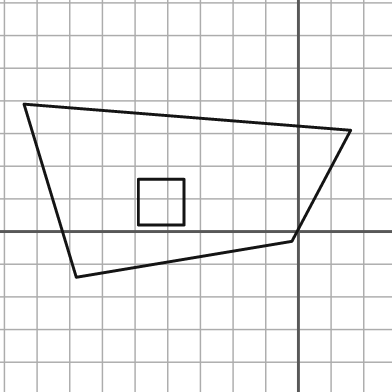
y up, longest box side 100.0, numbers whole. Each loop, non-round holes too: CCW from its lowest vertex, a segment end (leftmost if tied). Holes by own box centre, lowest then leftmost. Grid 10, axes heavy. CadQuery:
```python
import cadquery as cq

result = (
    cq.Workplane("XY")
    .moveTo(-68.0, -14.0)
    .lineTo(-2.0, -3.0)
    .lineTo(16.0, 31.0)
    .lineTo(-84.0, 39.0)
    .close()
    .moveTo(-49.0, 2.0)
    .lineTo(-35.0, 2.0)
    .lineTo(-35.0, 16.0)
    .lineTo(-49.0, 16.0)
    .close()
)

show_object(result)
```